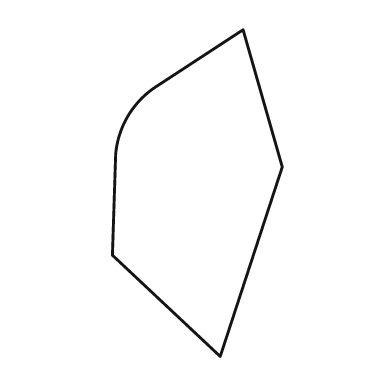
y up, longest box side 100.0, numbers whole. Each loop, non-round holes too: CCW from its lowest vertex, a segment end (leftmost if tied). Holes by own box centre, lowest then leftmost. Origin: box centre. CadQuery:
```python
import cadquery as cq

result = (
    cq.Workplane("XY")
    .moveTo(7.0, -50.0)
    .lineTo(26.0, 8.0)
    .lineTo(14.0, 50.0)
    .lineTo(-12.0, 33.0)
    .threePointArc((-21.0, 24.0), (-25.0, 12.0))
    .lineTo(-26.0, -19.0)
    .close()
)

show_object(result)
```